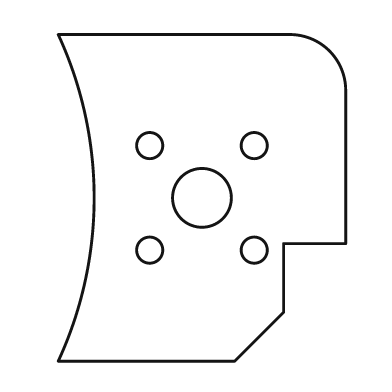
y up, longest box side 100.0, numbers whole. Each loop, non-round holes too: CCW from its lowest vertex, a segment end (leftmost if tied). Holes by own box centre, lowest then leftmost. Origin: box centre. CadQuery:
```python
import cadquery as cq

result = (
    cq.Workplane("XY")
    .moveTo(-44.0, -50.0)
    .lineTo(10.0, -50.0)
    .lineTo(25.0, -35.0)
    .lineTo(25.0, -14.0)
    .lineTo(44.0, -14.0)
    .lineTo(44.0, 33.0)
    .threePointArc((39.0, 45.0), (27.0, 50.0))
    .lineTo(-44.0, 50.0)
    .threePointArc((-33.0, 0.0), (-44.0, -50.0))
    .close()
    .moveTo(-16.0, -16.0)
    .circle(4.0)
    .moveTo(16.0, -16.0)
    .circle(4.0)
    .moveTo(0.0, 0.0)
    .circle(9.0)
    .moveTo(-16.0, 16.0)
    .circle(4.0)
    .moveTo(16.0, 16.0)
    .circle(4.0)
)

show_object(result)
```